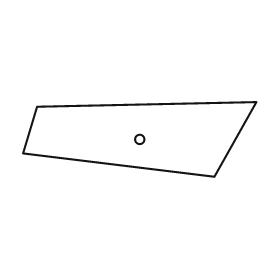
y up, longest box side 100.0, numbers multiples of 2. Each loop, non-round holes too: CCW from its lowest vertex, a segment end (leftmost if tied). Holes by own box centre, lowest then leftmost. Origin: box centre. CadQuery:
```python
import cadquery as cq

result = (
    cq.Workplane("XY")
    .moveTo(32.0, -16.0)
    .lineTo(50.0, 16.0)
    .lineTo(-44.0, 14.0)
    .lineTo(-50.0, -6.0)
    .close()
    .moveTo(0.0, 0.0)
    .circle(2.0)
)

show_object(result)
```